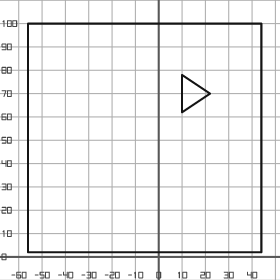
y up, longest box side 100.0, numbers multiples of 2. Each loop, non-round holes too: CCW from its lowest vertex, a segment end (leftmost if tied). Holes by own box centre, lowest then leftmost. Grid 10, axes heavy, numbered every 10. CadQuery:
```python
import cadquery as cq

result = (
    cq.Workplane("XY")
    .moveTo(-56.0, 2.0)
    .lineTo(44.0, 2.0)
    .lineTo(44.0, 100.0)
    .lineTo(-56.0, 100.0)
    .close()
    .moveTo(10.0, 62.0)
    .lineTo(22.0, 70.0)
    .lineTo(10.0, 78.0)
    .close()
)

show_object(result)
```